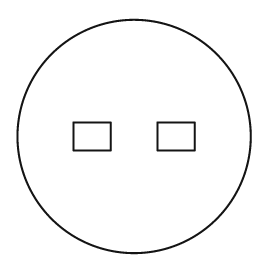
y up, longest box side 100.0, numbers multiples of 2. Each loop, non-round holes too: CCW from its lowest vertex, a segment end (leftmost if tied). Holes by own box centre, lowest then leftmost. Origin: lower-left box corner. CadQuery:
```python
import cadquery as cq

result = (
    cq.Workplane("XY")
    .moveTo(50.0, 50.0)
    .circle(50.0)
    .moveTo(24.0, 44.0)
    .lineTo(40.0, 44.0)
    .lineTo(40.0, 56.0)
    .lineTo(24.0, 56.0)
    .close()
    .moveTo(60.0, 44.0)
    .lineTo(76.0, 44.0)
    .lineTo(76.0, 56.0)
    .lineTo(60.0, 56.0)
    .close()
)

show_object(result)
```